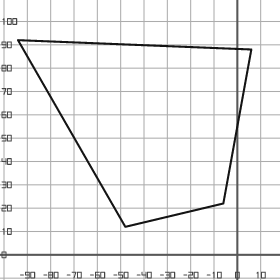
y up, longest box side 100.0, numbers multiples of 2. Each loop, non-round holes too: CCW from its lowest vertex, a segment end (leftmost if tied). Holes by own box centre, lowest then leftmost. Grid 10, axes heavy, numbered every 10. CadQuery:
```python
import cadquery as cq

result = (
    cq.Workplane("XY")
    .moveTo(-48.0, 12.0)
    .lineTo(-6.0, 22.0)
    .lineTo(6.0, 88.0)
    .lineTo(-94.0, 92.0)
    .close()
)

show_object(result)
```